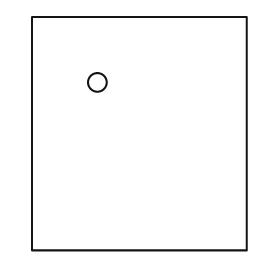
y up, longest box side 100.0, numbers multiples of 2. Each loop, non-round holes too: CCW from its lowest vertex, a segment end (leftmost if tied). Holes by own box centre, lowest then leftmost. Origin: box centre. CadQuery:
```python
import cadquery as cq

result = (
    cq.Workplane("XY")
    .moveTo(-46.0, -50.0)
    .lineTo(46.0, -50.0)
    .lineTo(46.0, 50.0)
    .lineTo(-46.0, 50.0)
    .close()
    .moveTo(-18.0, 22.0)
    .circle(4.0)
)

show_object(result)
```